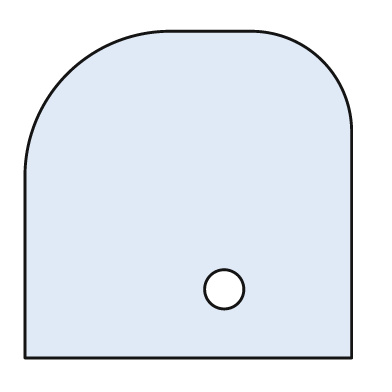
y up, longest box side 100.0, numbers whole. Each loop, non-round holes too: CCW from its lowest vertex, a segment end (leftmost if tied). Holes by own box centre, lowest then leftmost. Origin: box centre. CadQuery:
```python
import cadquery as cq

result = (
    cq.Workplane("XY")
    .moveTo(-50.0, -50.0)
    .lineTo(50.0, -50.0)
    .lineTo(50.0, 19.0)
    .threePointArc((41.0, 41.0), (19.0, 50.0))
    .lineTo(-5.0, 50.0)
    .threePointArc((-37.0, 37.0), (-50.0, 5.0))
    .close()
    .moveTo(11.0, -29.0)
    .circle(6.0)
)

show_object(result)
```